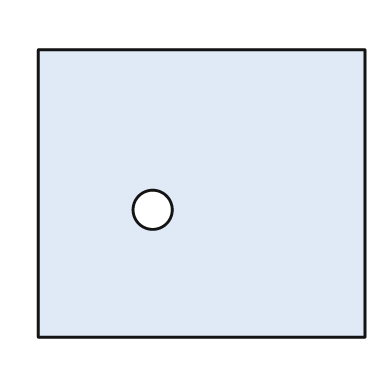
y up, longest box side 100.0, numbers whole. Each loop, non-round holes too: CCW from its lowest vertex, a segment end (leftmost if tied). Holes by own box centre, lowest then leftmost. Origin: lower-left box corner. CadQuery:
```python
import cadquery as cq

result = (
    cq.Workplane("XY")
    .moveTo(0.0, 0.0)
    .lineTo(100.0, 0.0)
    .lineTo(100.0, 88.0)
    .lineTo(0.0, 88.0)
    .close()
    .moveTo(35.0, 39.0)
    .circle(6.0)
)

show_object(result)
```